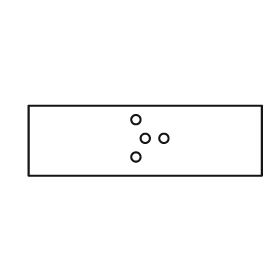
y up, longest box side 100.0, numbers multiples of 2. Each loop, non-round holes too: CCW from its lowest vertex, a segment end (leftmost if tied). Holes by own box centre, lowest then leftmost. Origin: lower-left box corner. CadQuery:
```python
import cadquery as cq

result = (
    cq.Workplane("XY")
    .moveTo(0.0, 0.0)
    .lineTo(100.0, 0.0)
    .lineTo(100.0, 30.0)
    .lineTo(0.0, 30.0)
    .close()
    .moveTo(46.0, 8.0)
    .circle(2.0)
    .moveTo(50.0, 16.0)
    .circle(2.0)
    .moveTo(58.0, 16.0)
    .circle(2.0)
    .moveTo(46.0, 24.0)
    .circle(2.0)
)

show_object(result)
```